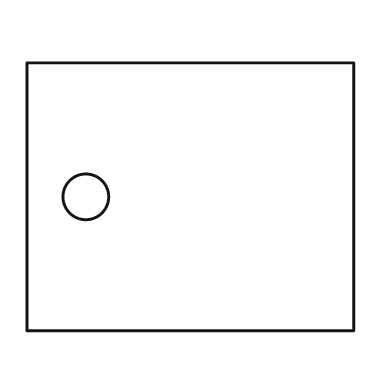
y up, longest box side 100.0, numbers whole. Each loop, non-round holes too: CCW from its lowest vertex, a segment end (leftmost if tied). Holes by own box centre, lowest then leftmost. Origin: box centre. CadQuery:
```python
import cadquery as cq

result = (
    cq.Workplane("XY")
    .moveTo(-50.0, -41.0)
    .lineTo(50.0, -41.0)
    .lineTo(50.0, 41.0)
    .lineTo(-50.0, 41.0)
    .close()
    .moveTo(-32.0, 0.0)
    .circle(7.0)
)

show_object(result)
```